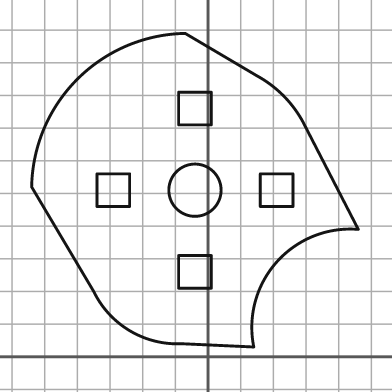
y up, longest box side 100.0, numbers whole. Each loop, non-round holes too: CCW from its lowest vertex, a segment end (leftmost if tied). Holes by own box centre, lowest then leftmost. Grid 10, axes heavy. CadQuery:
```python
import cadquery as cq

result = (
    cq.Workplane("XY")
    .moveTo(14.0, 3.0)
    .threePointArc((21.0, 29.0), (46.0, 39.0))
    .lineTo(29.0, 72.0)
    .threePointArc((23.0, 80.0), (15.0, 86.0))
    .lineTo(-7.0, 99.0)
    .threePointArc((-40.0, 85.0), (-54.0, 52.0))
    .lineTo(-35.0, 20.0)
    .threePointArc((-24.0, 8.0), (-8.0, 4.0))
    .close()
    .moveTo(-9.0, 21.0)
    .lineTo(1.0, 21.0)
    .lineTo(1.0, 31.0)
    .lineTo(-9.0, 31.0)
    .close()
    .moveTo(-34.0, 46.0)
    .lineTo(-24.0, 46.0)
    .lineTo(-24.0, 56.0)
    .lineTo(-34.0, 56.0)
    .close()
    .moveTo(-4.0, 51.0)
    .circle(8.0)
    .moveTo(16.0, 46.0)
    .lineTo(26.0, 46.0)
    .lineTo(26.0, 56.0)
    .lineTo(16.0, 56.0)
    .close()
    .moveTo(-9.0, 71.0)
    .lineTo(1.0, 71.0)
    .lineTo(1.0, 81.0)
    .lineTo(-9.0, 81.0)
    .close()
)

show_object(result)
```